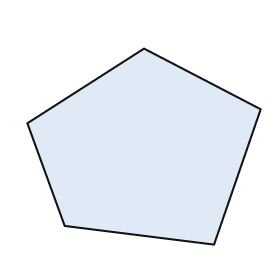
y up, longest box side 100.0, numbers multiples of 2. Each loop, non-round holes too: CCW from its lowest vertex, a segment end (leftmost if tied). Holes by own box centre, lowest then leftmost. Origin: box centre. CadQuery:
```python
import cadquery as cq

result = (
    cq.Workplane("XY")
    .moveTo(30.0, -42.0)
    .lineTo(50.0, 16.0)
    .lineTo(0.0, 42.0)
    .lineTo(-50.0, 10.0)
    .lineTo(-34.0, -34.0)
    .close()
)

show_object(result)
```